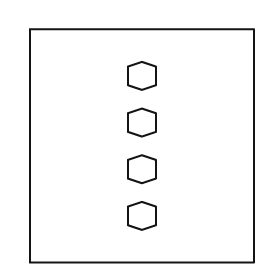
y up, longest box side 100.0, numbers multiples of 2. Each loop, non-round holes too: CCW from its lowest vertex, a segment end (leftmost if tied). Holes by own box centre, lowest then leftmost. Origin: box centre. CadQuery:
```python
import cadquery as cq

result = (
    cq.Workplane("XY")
    .moveTo(-48.0, -50.0)
    .lineTo(48.0, -50.0)
    .lineTo(48.0, 50.0)
    .lineTo(-48.0, 50.0)
    .close()
    .moveTo(0.0, -36.0)
    .lineTo(6.0, -34.0)
    .lineTo(6.0, -26.0)
    .lineTo(0.0, -24.0)
    .lineTo(-6.0, -26.0)
    .lineTo(-6.0, -34.0)
    .close()
    .moveTo(0.0, -16.0)
    .lineTo(6.0, -14.0)
    .lineTo(6.0, -6.0)
    .lineTo(0.0, -4.0)
    .lineTo(-6.0, -6.0)
    .lineTo(-6.0, -14.0)
    .close()
    .moveTo(0.0, 4.0)
    .lineTo(6.0, 6.0)
    .lineTo(6.0, 14.0)
    .lineTo(0.0, 16.0)
    .lineTo(-6.0, 14.0)
    .lineTo(-6.0, 6.0)
    .close()
    .moveTo(0.0, 24.0)
    .lineTo(6.0, 26.0)
    .lineTo(6.0, 34.0)
    .lineTo(0.0, 36.0)
    .lineTo(-6.0, 34.0)
    .lineTo(-6.0, 26.0)
    .close()
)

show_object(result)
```